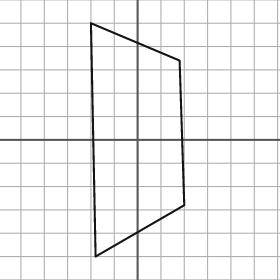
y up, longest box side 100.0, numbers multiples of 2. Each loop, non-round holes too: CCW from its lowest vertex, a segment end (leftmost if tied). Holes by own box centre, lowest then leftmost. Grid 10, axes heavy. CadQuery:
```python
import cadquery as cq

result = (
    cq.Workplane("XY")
    .moveTo(-18.0, -50.0)
    .lineTo(20.0, -28.0)
    .lineTo(18.0, 34.0)
    .lineTo(-20.0, 50.0)
    .close()
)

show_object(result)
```